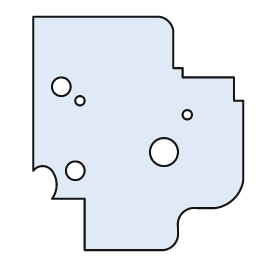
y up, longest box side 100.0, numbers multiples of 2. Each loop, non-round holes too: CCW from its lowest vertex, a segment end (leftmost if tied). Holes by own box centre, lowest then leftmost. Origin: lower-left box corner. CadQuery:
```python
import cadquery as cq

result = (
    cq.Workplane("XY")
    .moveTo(22.0, 0.0)
    .lineTo(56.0, 0.0)
    .threePointArc((60.0, 2.0), (62.0, 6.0))
    .lineTo(62.0, 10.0)
    .threePointArc((64.0, 16.0), (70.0, 18.0))
    .lineTo(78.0, 18.0)
    .threePointArc((86.0, 22.0), (90.0, 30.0))
    .lineTo(90.0, 64.0)
    .lineTo(86.0, 64.0)
    .lineTo(86.0, 74.0)
    .lineTo(64.0, 74.0)
    .lineTo(64.0, 78.0)
    .lineTo(60.0, 78.0)
    .lineTo(60.0, 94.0)
    .threePointArc((58.0, 98.0), (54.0, 100.0))
    .lineTo(0.0, 100.0)
    .lineTo(0.0, 34.0)
    .threePointArc((4.0, 36.0), (8.0, 34.0))
    .threePointArc((10.0, 28.0), (8.0, 22.0))
    .lineTo(22.0, 22.0)
    .close()
    .moveTo(18.0, 34.0)
    .circle(4.0)
    .moveTo(56.0, 42.0)
    .circle(6.0)
    .moveTo(66.0, 58.0)
    .circle(2.0)
    .moveTo(20.0, 64.0)
    .circle(2.0)
    .moveTo(12.0, 70.0)
    .circle(4.0)
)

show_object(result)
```